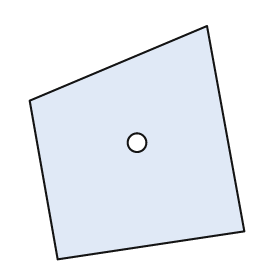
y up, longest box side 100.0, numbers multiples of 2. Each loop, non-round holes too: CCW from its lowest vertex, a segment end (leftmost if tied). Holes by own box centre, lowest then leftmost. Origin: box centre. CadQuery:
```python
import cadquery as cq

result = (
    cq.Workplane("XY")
    .moveTo(-34.0, -50.0)
    .lineTo(46.0, -38.0)
    .lineTo(30.0, 50.0)
    .lineTo(-46.0, 18.0)
    .close()
    .moveTo(0.0, 0.0)
    .circle(4.0)
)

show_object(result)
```